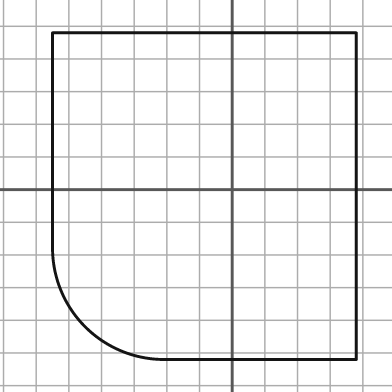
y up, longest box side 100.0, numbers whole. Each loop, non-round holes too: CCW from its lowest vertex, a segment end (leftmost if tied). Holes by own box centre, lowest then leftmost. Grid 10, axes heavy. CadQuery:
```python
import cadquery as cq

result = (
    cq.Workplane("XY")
    .moveTo(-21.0, -52.0)
    .lineTo(38.0, -52.0)
    .lineTo(38.0, 48.0)
    .lineTo(-55.0, 48.0)
    .lineTo(-55.0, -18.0)
    .threePointArc((-45.0, -42.0), (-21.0, -52.0))
    .close()
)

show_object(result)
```